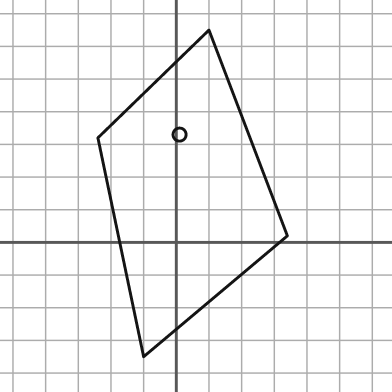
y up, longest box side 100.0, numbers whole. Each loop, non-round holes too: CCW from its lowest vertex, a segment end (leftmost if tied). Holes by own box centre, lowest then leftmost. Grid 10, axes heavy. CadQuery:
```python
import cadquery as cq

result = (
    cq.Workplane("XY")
    .moveTo(-10.0, -35.0)
    .lineTo(34.0, 2.0)
    .lineTo(10.0, 65.0)
    .lineTo(-24.0, 32.0)
    .close()
    .moveTo(1.0, 33.0)
    .circle(2.0)
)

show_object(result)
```